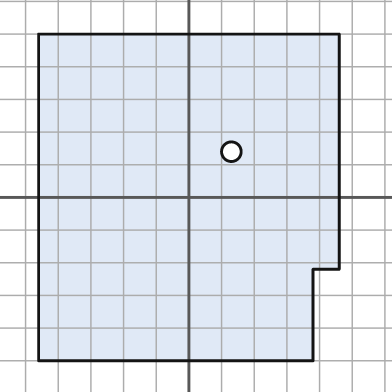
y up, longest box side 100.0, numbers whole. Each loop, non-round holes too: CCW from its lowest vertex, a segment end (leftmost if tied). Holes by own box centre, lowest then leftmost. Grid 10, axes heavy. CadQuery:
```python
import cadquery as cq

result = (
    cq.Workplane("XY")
    .moveTo(-46.0, -50.0)
    .lineTo(38.0, -50.0)
    .lineTo(38.0, -22.0)
    .lineTo(46.0, -22.0)
    .lineTo(46.0, 50.0)
    .lineTo(-46.0, 50.0)
    .close()
    .moveTo(13.0, 14.0)
    .circle(3.0)
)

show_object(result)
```